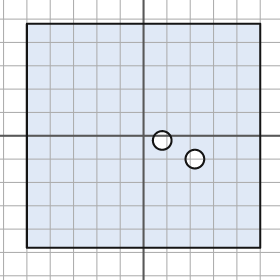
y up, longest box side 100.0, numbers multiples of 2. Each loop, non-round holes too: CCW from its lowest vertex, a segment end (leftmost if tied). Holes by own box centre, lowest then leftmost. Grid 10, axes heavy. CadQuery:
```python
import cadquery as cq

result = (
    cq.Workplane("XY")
    .moveTo(-50.0, -48.0)
    .lineTo(50.0, -48.0)
    .lineTo(50.0, 48.0)
    .lineTo(-50.0, 48.0)
    .close()
    .moveTo(22.0, -10.0)
    .circle(4.0)
    .moveTo(8.0, -2.0)
    .circle(4.0)
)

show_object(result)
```